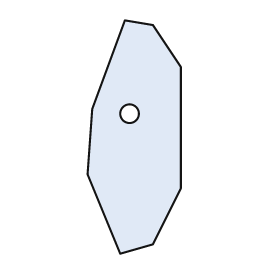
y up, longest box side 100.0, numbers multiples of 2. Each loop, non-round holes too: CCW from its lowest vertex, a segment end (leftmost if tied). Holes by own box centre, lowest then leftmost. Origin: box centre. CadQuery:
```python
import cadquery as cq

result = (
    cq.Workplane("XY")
    .moveTo(-6.0, -50.0)
    .lineTo(8.0, -46.0)
    .lineTo(20.0, -22.0)
    .lineTo(20.0, 30.0)
    .lineTo(8.0, 48.0)
    .lineTo(-4.0, 50.0)
    .lineTo(-18.0, 12.0)
    .lineTo(-20.0, -16.0)
    .close()
    .moveTo(-2.0, 10.0)
    .circle(4.0)
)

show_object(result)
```